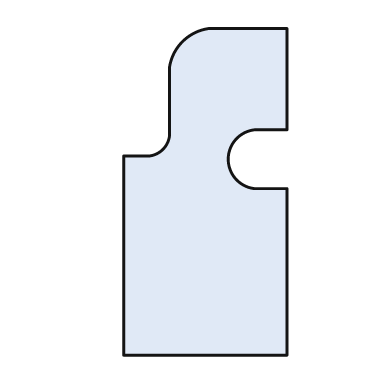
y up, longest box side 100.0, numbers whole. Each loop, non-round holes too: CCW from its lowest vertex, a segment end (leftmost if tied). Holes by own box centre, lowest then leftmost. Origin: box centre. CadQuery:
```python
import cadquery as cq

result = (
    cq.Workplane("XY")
    .moveTo(-25.0, -50.0)
    .lineTo(25.0, -50.0)
    .lineTo(25.0, 1.0)
    .lineTo(15.0, 1.0)
    .threePointArc((7.0, 10.0), (15.0, 19.0))
    .lineTo(25.0, 19.0)
    .lineTo(25.0, 50.0)
    .lineTo(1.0, 50.0)
    .threePointArc((-7.0, 46.0), (-11.0, 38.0))
    .lineTo(-11.0, 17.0)
    .threePointArc((-13.0, 13.0), (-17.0, 11.0))
    .lineTo(-25.0, 11.0)
    .close()
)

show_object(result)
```